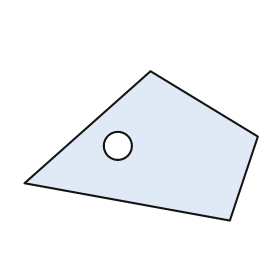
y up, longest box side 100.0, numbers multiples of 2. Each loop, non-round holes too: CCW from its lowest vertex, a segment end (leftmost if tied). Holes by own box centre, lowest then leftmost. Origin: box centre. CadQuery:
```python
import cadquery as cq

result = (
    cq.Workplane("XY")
    .moveTo(38.0, -32.0)
    .lineTo(50.0, 4.0)
    .lineTo(4.0, 32.0)
    .lineTo(-50.0, -16.0)
    .close()
    .moveTo(-10.0, 0.0)
    .circle(6.0)
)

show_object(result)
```